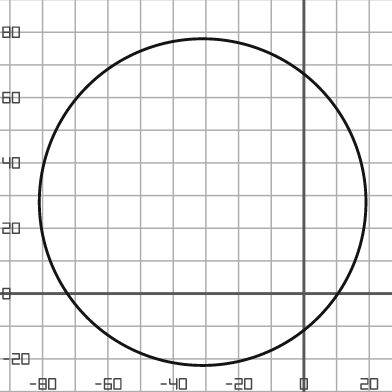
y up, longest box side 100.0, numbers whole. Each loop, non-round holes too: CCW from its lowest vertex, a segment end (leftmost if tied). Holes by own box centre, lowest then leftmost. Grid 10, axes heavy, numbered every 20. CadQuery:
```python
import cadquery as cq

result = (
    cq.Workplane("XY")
    .moveTo(-31.0, 28.0)
    .circle(50.0)
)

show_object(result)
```